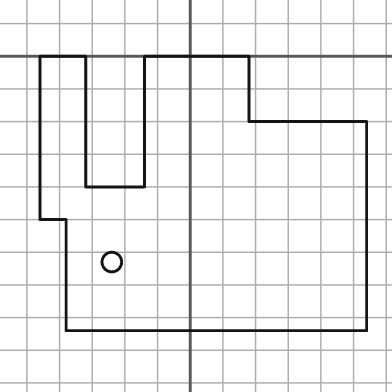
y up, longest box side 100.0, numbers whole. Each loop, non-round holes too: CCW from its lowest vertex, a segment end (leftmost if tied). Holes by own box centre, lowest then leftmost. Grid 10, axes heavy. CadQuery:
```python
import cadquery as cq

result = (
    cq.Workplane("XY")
    .moveTo(-38.0, -84.0)
    .lineTo(54.0, -84.0)
    .lineTo(54.0, -20.0)
    .lineTo(18.0, -20.0)
    .lineTo(18.0, 0.0)
    .lineTo(-14.0, 0.0)
    .lineTo(-14.0, -40.0)
    .lineTo(-32.0, -40.0)
    .lineTo(-32.0, 0.0)
    .lineTo(-46.0, 0.0)
    .lineTo(-46.0, -50.0)
    .lineTo(-38.0, -50.0)
    .close()
    .moveTo(-24.0, -63.0)
    .circle(3.0)
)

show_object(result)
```